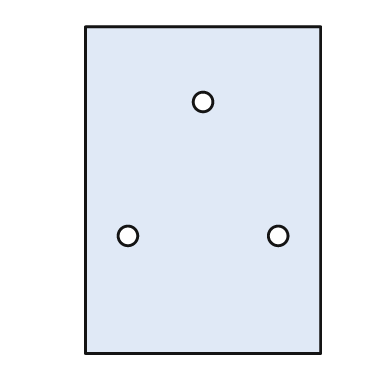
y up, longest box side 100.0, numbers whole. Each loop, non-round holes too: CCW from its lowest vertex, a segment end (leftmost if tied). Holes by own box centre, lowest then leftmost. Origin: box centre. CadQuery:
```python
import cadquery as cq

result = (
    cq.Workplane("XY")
    .moveTo(-36.0, -50.0)
    .lineTo(36.0, -50.0)
    .lineTo(36.0, 50.0)
    .lineTo(-36.0, 50.0)
    .close()
    .moveTo(-23.0, -14.0)
    .circle(3.0)
    .moveTo(23.0, -14.0)
    .circle(3.0)
    .moveTo(0.0, 27.0)
    .circle(3.0)
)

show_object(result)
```